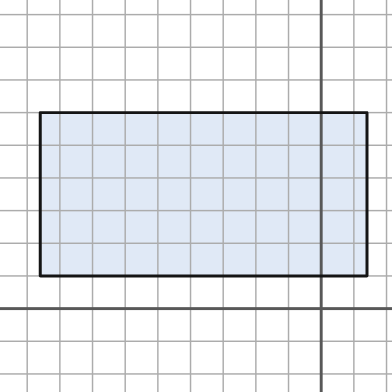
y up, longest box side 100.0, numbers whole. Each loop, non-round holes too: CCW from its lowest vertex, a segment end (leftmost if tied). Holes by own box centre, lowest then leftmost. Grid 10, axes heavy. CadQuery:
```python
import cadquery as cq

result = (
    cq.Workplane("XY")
    .moveTo(-86.0, 10.0)
    .lineTo(14.0, 10.0)
    .lineTo(14.0, 60.0)
    .lineTo(-86.0, 60.0)
    .close()
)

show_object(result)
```